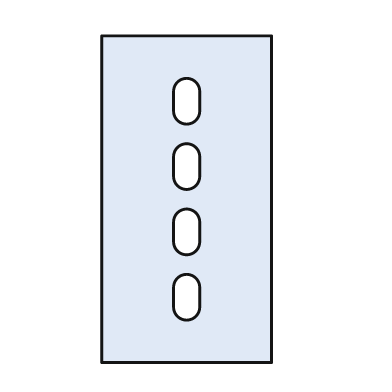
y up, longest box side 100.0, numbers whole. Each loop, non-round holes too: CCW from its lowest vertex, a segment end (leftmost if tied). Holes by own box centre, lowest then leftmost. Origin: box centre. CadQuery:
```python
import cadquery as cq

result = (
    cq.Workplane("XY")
    .moveTo(-26.0, -50.0)
    .lineTo(26.0, -50.0)
    .lineTo(26.0, 50.0)
    .lineTo(-26.0, 50.0)
    .close()
    .moveTo(-4.0, -33.0)
    .threePointArc((0.0, -37.0), (4.0, -33.0))
    .lineTo(4.0, -27.0)
    .threePointArc((0.0, -23.0), (-4.0, -27.0))
    .close()
    .moveTo(-4.0, -13.0)
    .threePointArc((0.0, -17.0), (4.0, -13.0))
    .lineTo(4.0, -7.0)
    .threePointArc((0.0, -3.0), (-4.0, -7.0))
    .close()
    .moveTo(-4.0, 7.0)
    .threePointArc((0.0, 3.0), (4.0, 7.0))
    .lineTo(4.0, 13.0)
    .threePointArc((0.0, 17.0), (-4.0, 13.0))
    .close()
    .moveTo(-4.0, 27.0)
    .threePointArc((0.0, 23.0), (4.0, 27.0))
    .lineTo(4.0, 33.0)
    .threePointArc((0.0, 37.0), (-4.0, 33.0))
    .close()
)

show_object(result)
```